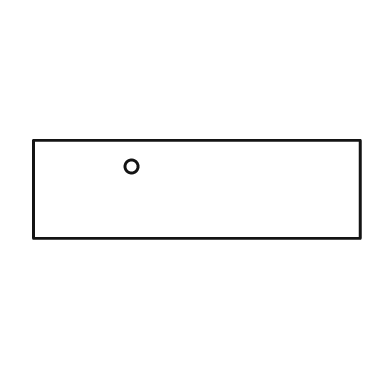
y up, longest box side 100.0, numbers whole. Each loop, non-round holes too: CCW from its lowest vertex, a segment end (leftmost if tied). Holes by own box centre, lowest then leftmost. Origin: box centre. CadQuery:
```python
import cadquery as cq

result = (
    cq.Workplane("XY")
    .moveTo(-50.0, -15.0)
    .lineTo(50.0, -15.0)
    .lineTo(50.0, 15.0)
    .lineTo(-50.0, 15.0)
    .close()
    .moveTo(-20.0, 7.0)
    .circle(2.0)
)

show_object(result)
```